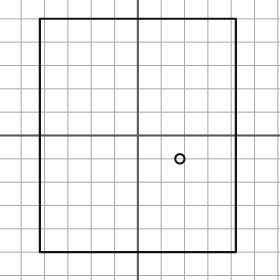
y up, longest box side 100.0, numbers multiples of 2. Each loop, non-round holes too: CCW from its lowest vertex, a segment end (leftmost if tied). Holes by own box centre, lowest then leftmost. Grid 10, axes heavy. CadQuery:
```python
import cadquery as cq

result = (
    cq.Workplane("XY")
    .moveTo(-42.0, -50.0)
    .lineTo(42.0, -50.0)
    .lineTo(42.0, 50.0)
    .lineTo(-42.0, 50.0)
    .close()
    .moveTo(18.0, -10.0)
    .circle(2.0)
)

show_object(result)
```